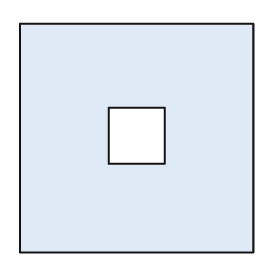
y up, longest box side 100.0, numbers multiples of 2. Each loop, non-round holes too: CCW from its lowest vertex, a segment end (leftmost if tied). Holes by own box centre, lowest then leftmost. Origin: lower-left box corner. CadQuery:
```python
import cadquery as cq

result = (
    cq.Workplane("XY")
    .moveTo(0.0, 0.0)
    .lineTo(100.0, 0.0)
    .lineTo(100.0, 98.0)
    .lineTo(0.0, 98.0)
    .close()
    .moveTo(38.0, 38.0)
    .lineTo(62.0, 38.0)
    .lineTo(62.0, 62.0)
    .lineTo(38.0, 62.0)
    .close()
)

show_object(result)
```